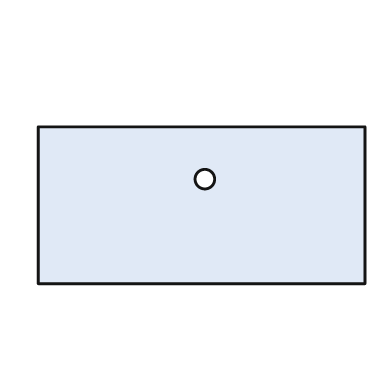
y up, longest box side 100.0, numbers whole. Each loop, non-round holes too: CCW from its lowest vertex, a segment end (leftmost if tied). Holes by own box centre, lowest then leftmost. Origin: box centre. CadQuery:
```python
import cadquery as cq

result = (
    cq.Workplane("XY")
    .moveTo(-50.0, -24.0)
    .lineTo(50.0, -24.0)
    .lineTo(50.0, 24.0)
    .lineTo(-50.0, 24.0)
    .close()
    .moveTo(1.0, 8.0)
    .circle(3.0)
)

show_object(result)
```